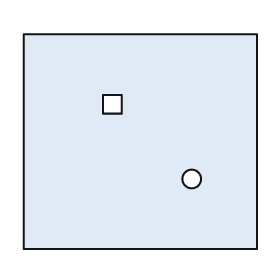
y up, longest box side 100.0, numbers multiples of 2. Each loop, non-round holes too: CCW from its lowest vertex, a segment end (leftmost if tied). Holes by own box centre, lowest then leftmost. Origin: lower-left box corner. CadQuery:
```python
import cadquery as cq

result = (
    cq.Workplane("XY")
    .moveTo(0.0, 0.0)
    .lineTo(100.0, 0.0)
    .lineTo(100.0, 92.0)
    .lineTo(0.0, 92.0)
    .close()
    .moveTo(72.0, 30.0)
    .circle(4.0)
    .moveTo(34.0, 58.0)
    .lineTo(42.0, 58.0)
    .lineTo(42.0, 66.0)
    .lineTo(34.0, 66.0)
    .close()
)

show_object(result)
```